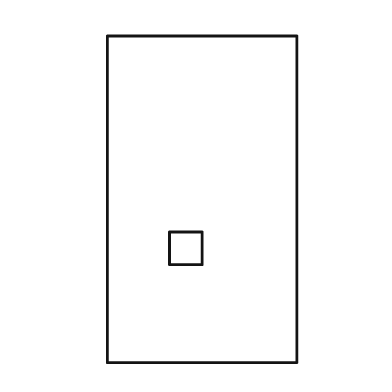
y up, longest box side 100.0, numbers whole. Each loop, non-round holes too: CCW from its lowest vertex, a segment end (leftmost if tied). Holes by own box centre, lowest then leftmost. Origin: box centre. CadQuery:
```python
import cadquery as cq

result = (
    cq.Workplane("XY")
    .moveTo(-29.0, -50.0)
    .lineTo(29.0, -50.0)
    .lineTo(29.0, 50.0)
    .lineTo(-29.0, 50.0)
    .close()
    .moveTo(-10.0, -20.0)
    .lineTo(0.0, -20.0)
    .lineTo(0.0, -10.0)
    .lineTo(-10.0, -10.0)
    .close()
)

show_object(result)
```